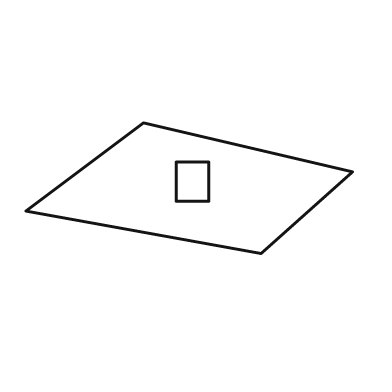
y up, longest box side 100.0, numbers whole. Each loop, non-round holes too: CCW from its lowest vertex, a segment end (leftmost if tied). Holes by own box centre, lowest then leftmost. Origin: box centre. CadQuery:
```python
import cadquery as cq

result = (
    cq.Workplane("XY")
    .moveTo(22.0, -20.0)
    .lineTo(50.0, 5.0)
    .lineTo(-14.0, 20.0)
    .lineTo(-50.0, -7.0)
    .close()
    .moveTo(-4.0, -4.0)
    .lineTo(6.0, -4.0)
    .lineTo(6.0, 8.0)
    .lineTo(-4.0, 8.0)
    .close()
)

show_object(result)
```